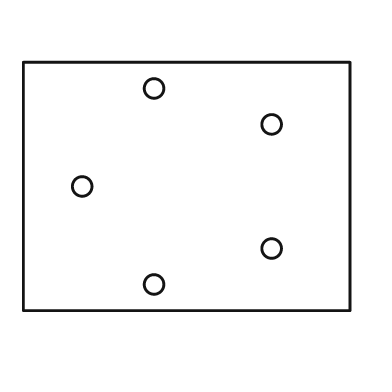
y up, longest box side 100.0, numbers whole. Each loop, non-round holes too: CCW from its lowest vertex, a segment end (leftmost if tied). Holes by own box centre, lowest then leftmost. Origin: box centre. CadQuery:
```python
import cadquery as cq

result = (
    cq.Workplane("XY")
    .moveTo(-50.0, -38.0)
    .lineTo(50.0, -38.0)
    .lineTo(50.0, 38.0)
    .lineTo(-50.0, 38.0)
    .close()
    .moveTo(-10.0, -30.0)
    .circle(3.0)
    .moveTo(26.0, -19.0)
    .circle(3.0)
    .moveTo(-32.0, 0.0)
    .circle(3.0)
    .moveTo(26.0, 19.0)
    .circle(3.0)
    .moveTo(-10.0, 30.0)
    .circle(3.0)
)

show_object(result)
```